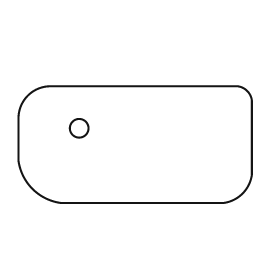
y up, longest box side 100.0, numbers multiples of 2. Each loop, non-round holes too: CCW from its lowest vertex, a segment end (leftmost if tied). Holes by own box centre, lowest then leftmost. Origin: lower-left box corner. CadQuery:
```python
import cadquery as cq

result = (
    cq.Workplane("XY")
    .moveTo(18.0, 0.0)
    .lineTo(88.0, 0.0)
    .threePointArc((96.0, 4.0), (100.0, 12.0))
    .lineTo(100.0, 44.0)
    .threePointArc((98.0, 48.0), (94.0, 50.0))
    .lineTo(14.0, 50.0)
    .threePointArc((4.0, 46.0), (0.0, 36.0))
    .lineTo(0.0, 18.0)
    .threePointArc((6.0, 6.0), (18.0, 0.0))
    .close()
    .moveTo(26.0, 32.0)
    .circle(4.0)
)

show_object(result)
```